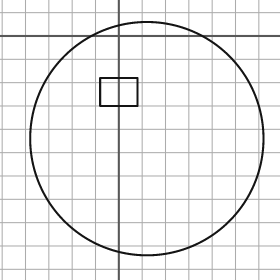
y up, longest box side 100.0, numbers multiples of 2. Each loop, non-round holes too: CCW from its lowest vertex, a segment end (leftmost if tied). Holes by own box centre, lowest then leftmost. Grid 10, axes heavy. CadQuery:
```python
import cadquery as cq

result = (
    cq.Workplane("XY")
    .moveTo(12.0, -44.0)
    .circle(50.0)
    .moveTo(-8.0, -30.0)
    .lineTo(8.0, -30.0)
    .lineTo(8.0, -18.0)
    .lineTo(-8.0, -18.0)
    .close()
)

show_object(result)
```